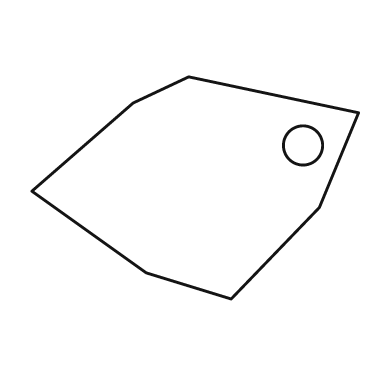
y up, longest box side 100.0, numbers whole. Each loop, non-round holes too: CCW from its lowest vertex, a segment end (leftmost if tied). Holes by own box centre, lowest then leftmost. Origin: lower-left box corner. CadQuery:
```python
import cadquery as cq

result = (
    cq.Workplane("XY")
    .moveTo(61.0, 0.0)
    .lineTo(88.0, 28.0)
    .lineTo(100.0, 57.0)
    .lineTo(48.0, 68.0)
    .lineTo(31.0, 60.0)
    .lineTo(0.0, 33.0)
    .lineTo(35.0, 8.0)
    .close()
    .moveTo(83.0, 47.0)
    .circle(6.0)
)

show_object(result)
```